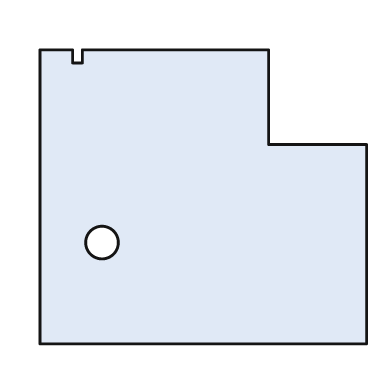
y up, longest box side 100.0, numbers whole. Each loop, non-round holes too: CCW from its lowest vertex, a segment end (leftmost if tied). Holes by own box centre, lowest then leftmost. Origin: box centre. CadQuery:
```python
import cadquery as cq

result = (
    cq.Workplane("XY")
    .moveTo(-50.0, -45.0)
    .lineTo(50.0, -45.0)
    .lineTo(50.0, 16.0)
    .lineTo(20.0, 16.0)
    .lineTo(20.0, 45.0)
    .lineTo(-37.0, 45.0)
    .lineTo(-37.0, 41.0)
    .lineTo(-40.0, 41.0)
    .lineTo(-40.0, 45.0)
    .lineTo(-50.0, 45.0)
    .close()
    .moveTo(-31.0, -14.0)
    .circle(5.0)
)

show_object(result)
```